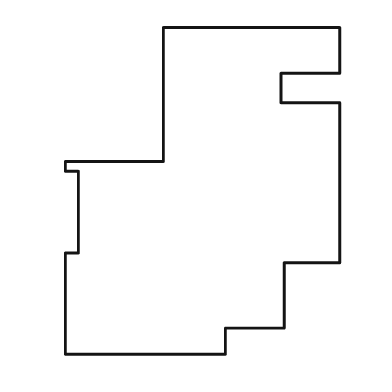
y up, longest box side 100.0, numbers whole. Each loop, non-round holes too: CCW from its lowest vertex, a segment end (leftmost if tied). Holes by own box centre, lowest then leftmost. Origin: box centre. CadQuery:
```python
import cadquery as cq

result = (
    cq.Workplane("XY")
    .moveTo(-42.0, -50.0)
    .lineTo(7.0, -50.0)
    .lineTo(7.0, -42.0)
    .lineTo(25.0, -42.0)
    .lineTo(25.0, -22.0)
    .lineTo(42.0, -22.0)
    .lineTo(42.0, 27.0)
    .lineTo(24.0, 27.0)
    .lineTo(24.0, 36.0)
    .lineTo(42.0, 36.0)
    .lineTo(42.0, 50.0)
    .lineTo(-12.0, 50.0)
    .lineTo(-12.0, 9.0)
    .lineTo(-42.0, 9.0)
    .lineTo(-42.0, 6.0)
    .lineTo(-38.0, 6.0)
    .lineTo(-38.0, -19.0)
    .lineTo(-42.0, -19.0)
    .close()
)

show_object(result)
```